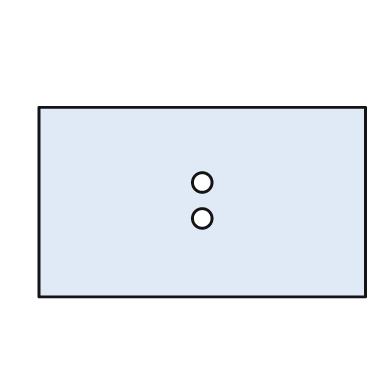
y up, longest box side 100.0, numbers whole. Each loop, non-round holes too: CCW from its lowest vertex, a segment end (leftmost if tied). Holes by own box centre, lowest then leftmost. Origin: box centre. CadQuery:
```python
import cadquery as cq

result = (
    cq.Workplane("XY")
    .moveTo(-50.0, -29.0)
    .lineTo(50.0, -29.0)
    .lineTo(50.0, 29.0)
    .lineTo(-50.0, 29.0)
    .close()
    .moveTo(0.0, -5.0)
    .circle(3.0)
    .moveTo(0.0, 6.0)
    .circle(3.0)
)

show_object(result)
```